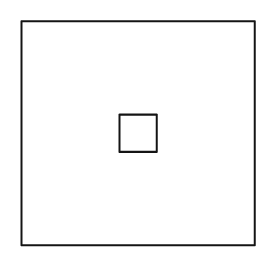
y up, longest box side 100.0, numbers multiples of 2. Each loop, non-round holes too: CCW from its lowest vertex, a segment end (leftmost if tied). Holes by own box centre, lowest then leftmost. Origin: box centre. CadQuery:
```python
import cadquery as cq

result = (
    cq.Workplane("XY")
    .moveTo(-50.0, -48.0)
    .lineTo(50.0, -48.0)
    .lineTo(50.0, 48.0)
    .lineTo(-50.0, 48.0)
    .close()
    .moveTo(-8.0, -8.0)
    .lineTo(8.0, -8.0)
    .lineTo(8.0, 8.0)
    .lineTo(-8.0, 8.0)
    .close()
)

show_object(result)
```